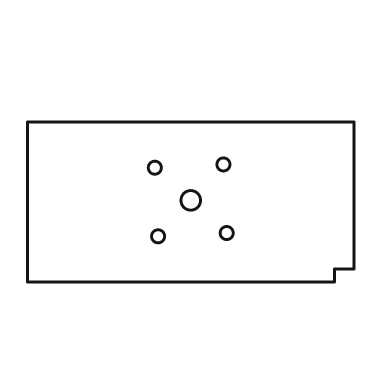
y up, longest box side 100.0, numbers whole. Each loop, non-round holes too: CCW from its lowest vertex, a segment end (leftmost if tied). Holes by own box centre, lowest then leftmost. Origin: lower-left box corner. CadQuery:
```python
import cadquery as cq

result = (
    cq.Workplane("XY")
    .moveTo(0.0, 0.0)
    .lineTo(94.0, 0.0)
    .lineTo(94.0, 4.0)
    .lineTo(100.0, 4.0)
    .lineTo(100.0, 49.0)
    .lineTo(0.0, 49.0)
    .close()
    .moveTo(40.0, 14.0)
    .circle(2.0)
    .moveTo(61.0, 15.0)
    .circle(2.0)
    .moveTo(50.0, 25.0)
    .circle(3.0)
    .moveTo(39.0, 35.0)
    .circle(2.0)
    .moveTo(60.0, 36.0)
    .circle(2.0)
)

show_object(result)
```